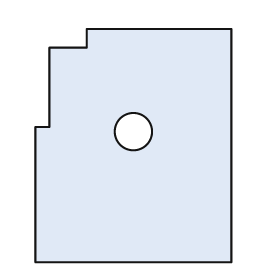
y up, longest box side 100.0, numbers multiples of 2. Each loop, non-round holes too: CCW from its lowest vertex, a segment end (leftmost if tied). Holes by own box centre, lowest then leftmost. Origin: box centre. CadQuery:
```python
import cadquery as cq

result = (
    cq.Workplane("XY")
    .moveTo(-42.0, -50.0)
    .lineTo(42.0, -50.0)
    .lineTo(42.0, 50.0)
    .lineTo(-20.0, 50.0)
    .lineTo(-20.0, 42.0)
    .lineTo(-36.0, 42.0)
    .lineTo(-36.0, 8.0)
    .lineTo(-42.0, 8.0)
    .close()
    .moveTo(0.0, 6.0)
    .circle(8.0)
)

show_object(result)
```